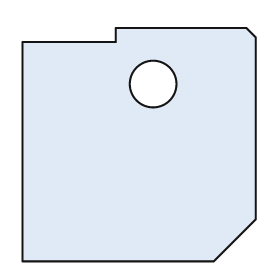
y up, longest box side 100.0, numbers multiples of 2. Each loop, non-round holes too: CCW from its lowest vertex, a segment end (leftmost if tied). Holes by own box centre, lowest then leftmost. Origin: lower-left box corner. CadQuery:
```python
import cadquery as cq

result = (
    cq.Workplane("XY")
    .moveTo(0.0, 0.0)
    .lineTo(82.0, 0.0)
    .lineTo(100.0, 18.0)
    .lineTo(100.0, 96.0)
    .lineTo(96.0, 100.0)
    .lineTo(40.0, 100.0)
    .lineTo(40.0, 94.0)
    .lineTo(0.0, 94.0)
    .close()
    .moveTo(56.0, 76.0)
    .circle(10.0)
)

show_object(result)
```